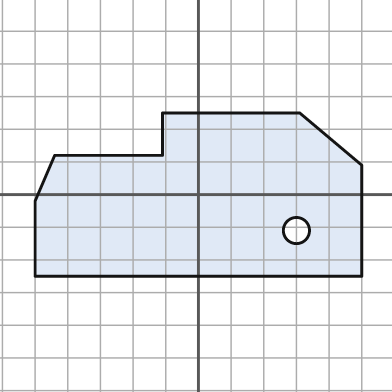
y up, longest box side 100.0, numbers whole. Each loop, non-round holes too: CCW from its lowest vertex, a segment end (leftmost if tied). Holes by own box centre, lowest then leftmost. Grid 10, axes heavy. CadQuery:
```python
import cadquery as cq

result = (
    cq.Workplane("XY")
    .moveTo(-50.0, -25.0)
    .lineTo(50.0, -25.0)
    .lineTo(50.0, 9.0)
    .lineTo(31.0, 25.0)
    .lineTo(-11.0, 25.0)
    .lineTo(-11.0, 12.0)
    .lineTo(-44.0, 12.0)
    .lineTo(-50.0, -2.0)
    .close()
    .moveTo(30.0, -11.0)
    .circle(4.0)
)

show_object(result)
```